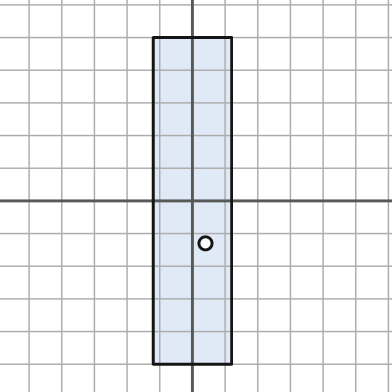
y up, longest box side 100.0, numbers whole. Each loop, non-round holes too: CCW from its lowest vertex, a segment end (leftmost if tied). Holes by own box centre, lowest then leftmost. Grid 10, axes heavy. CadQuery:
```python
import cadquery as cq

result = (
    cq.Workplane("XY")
    .moveTo(-12.0, -50.0)
    .lineTo(12.0, -50.0)
    .lineTo(12.0, 50.0)
    .lineTo(-12.0, 50.0)
    .close()
    .moveTo(4.0, -13.0)
    .circle(2.0)
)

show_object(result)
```